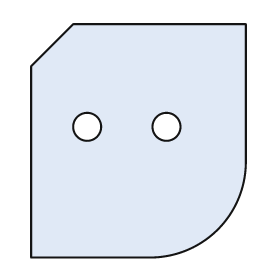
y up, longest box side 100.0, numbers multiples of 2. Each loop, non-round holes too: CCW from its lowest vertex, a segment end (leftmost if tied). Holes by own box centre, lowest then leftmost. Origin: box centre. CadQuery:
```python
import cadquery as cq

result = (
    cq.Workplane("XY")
    .moveTo(-46.0, -50.0)
    .lineTo(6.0, -50.0)
    .threePointArc((34.0, -38.0), (46.0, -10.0))
    .lineTo(46.0, 50.0)
    .lineTo(-28.0, 50.0)
    .lineTo(-46.0, 32.0)
    .close()
    .moveTo(-22.0, 6.0)
    .circle(6.0)
    .moveTo(12.0, 6.0)
    .circle(6.0)
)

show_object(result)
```